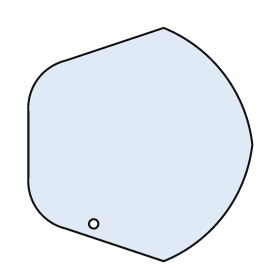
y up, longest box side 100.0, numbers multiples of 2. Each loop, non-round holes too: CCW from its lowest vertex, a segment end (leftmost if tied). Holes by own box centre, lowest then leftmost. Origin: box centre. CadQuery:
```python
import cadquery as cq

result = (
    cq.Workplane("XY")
    .moveTo(10.0, -50.0)
    .threePointArc((36.0, -30.0), (48.0, 0.0))
    .threePointArc((36.0, 30.0), (10.0, 50.0))
    .lineTo(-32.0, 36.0)
    .threePointArc((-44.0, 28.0), (-48.0, 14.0))
    .lineTo(-48.0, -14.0)
    .threePointArc((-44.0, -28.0), (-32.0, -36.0))
    .close()
    .moveTo(-20.0, -34.0)
    .circle(2.0)
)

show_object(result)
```